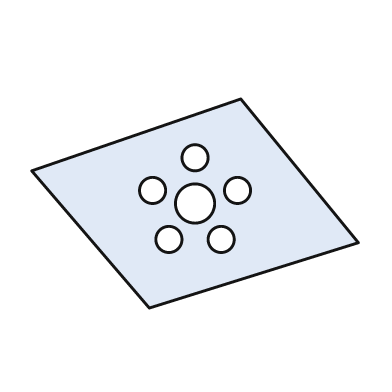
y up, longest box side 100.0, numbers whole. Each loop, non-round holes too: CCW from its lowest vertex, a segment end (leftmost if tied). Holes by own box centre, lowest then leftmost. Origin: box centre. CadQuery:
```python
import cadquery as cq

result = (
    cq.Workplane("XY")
    .moveTo(-14.0, -32.0)
    .lineTo(50.0, -12.0)
    .lineTo(14.0, 32.0)
    .lineTo(-50.0, 10.0)
    .close()
    .moveTo(-8.0, -11.0)
    .circle(4.0)
    .moveTo(8.0, -11.0)
    .circle(4.0)
    .moveTo(0.0, 0.0)
    .circle(6.0)
    .moveTo(-13.0, 4.0)
    .circle(4.0)
    .moveTo(13.0, 4.0)
    .circle(4.0)
    .moveTo(0.0, 14.0)
    .circle(4.0)
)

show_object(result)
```